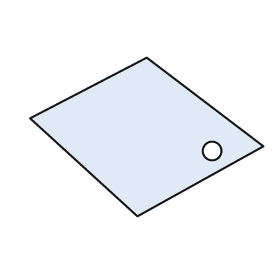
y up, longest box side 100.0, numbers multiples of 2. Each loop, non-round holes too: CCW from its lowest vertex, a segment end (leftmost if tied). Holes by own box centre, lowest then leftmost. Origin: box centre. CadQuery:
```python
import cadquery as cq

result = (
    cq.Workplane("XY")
    .moveTo(-4.0, -34.0)
    .lineTo(50.0, -4.0)
    .lineTo(0.0, 34.0)
    .lineTo(-50.0, 8.0)
    .close()
    .moveTo(28.0, -6.0)
    .circle(4.0)
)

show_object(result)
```